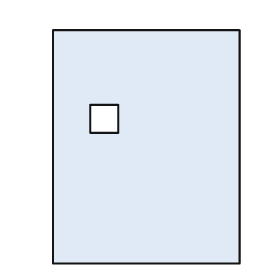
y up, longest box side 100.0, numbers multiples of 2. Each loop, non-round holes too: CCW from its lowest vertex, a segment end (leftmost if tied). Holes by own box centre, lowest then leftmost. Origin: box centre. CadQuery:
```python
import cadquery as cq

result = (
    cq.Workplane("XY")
    .moveTo(-40.0, -50.0)
    .lineTo(40.0, -50.0)
    .lineTo(40.0, 50.0)
    .lineTo(-40.0, 50.0)
    .close()
    .moveTo(-24.0, 6.0)
    .lineTo(-12.0, 6.0)
    .lineTo(-12.0, 18.0)
    .lineTo(-24.0, 18.0)
    .close()
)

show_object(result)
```